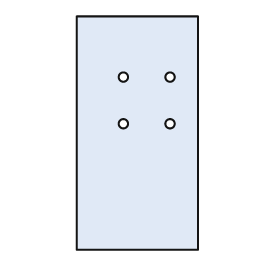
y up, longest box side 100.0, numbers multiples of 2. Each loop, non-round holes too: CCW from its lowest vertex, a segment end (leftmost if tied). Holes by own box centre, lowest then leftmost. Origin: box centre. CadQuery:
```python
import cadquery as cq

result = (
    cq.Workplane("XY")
    .moveTo(-26.0, -50.0)
    .lineTo(26.0, -50.0)
    .lineTo(26.0, 50.0)
    .lineTo(-26.0, 50.0)
    .close()
    .moveTo(-6.0, 4.0)
    .circle(2.0)
    .moveTo(14.0, 4.0)
    .circle(2.0)
    .moveTo(-6.0, 24.0)
    .circle(2.0)
    .moveTo(14.0, 24.0)
    .circle(2.0)
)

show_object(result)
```